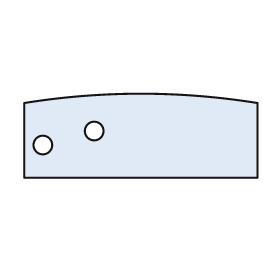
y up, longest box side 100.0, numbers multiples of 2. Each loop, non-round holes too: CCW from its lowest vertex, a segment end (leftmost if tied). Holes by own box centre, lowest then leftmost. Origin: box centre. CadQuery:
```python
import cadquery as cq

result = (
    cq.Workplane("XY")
    .moveTo(-50.0, -18.0)
    .lineTo(50.0, -18.0)
    .lineTo(50.0, 14.0)
    .threePointArc((0.0, 18.0), (-50.0, 14.0))
    .close()
    .moveTo(-42.0, -4.0)
    .circle(4.0)
    .moveTo(-20.0, 2.0)
    .circle(4.0)
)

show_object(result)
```